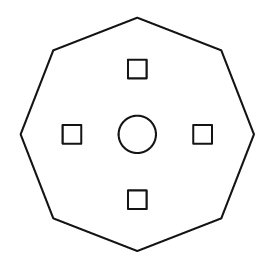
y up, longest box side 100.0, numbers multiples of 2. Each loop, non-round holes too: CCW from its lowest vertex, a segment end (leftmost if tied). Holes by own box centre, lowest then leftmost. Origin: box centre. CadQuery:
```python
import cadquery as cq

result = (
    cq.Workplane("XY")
    .moveTo(0.0, -50.0)
    .lineTo(36.0, -36.0)
    .lineTo(50.0, 0.0)
    .lineTo(36.0, 36.0)
    .lineTo(0.0, 50.0)
    .lineTo(-36.0, 36.0)
    .lineTo(-50.0, 0.0)
    .lineTo(-36.0, -36.0)
    .close()
    .moveTo(-4.0, -32.0)
    .lineTo(4.0, -32.0)
    .lineTo(4.0, -24.0)
    .lineTo(-4.0, -24.0)
    .close()
    .moveTo(-32.0, -4.0)
    .lineTo(-24.0, -4.0)
    .lineTo(-24.0, 4.0)
    .lineTo(-32.0, 4.0)
    .close()
    .moveTo(0.0, 0.0)
    .circle(8.0)
    .moveTo(24.0, -4.0)
    .lineTo(32.0, -4.0)
    .lineTo(32.0, 4.0)
    .lineTo(24.0, 4.0)
    .close()
    .moveTo(-4.0, 24.0)
    .lineTo(4.0, 24.0)
    .lineTo(4.0, 32.0)
    .lineTo(-4.0, 32.0)
    .close()
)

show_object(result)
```